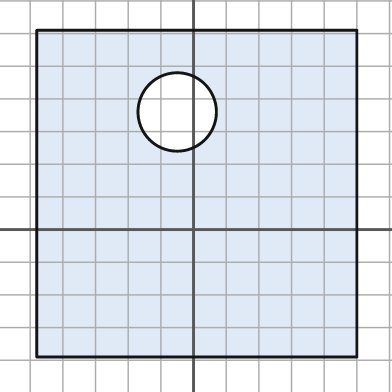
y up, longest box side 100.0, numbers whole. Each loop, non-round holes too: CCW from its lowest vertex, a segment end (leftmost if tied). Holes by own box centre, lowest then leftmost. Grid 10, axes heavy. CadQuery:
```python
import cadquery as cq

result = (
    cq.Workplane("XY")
    .moveTo(-48.0, -39.0)
    .lineTo(50.0, -39.0)
    .lineTo(50.0, 61.0)
    .lineTo(-48.0, 61.0)
    .close()
    .moveTo(-5.0, 36.0)
    .circle(12.0)
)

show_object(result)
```